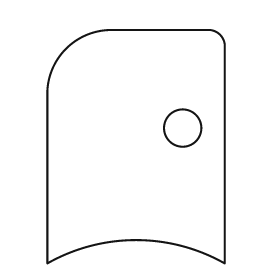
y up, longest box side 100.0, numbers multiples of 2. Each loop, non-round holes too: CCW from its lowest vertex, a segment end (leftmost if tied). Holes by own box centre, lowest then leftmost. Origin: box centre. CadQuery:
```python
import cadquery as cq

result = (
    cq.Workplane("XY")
    .moveTo(-38.0, -50.0)
    .threePointArc((0.0, -40.0), (38.0, -50.0))
    .lineTo(38.0, 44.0)
    .threePointArc((36.0, 48.0), (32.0, 50.0))
    .lineTo(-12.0, 50.0)
    .threePointArc((-30.0, 42.0), (-38.0, 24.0))
    .close()
    .moveTo(20.0, 8.0)
    .circle(8.0)
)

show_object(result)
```